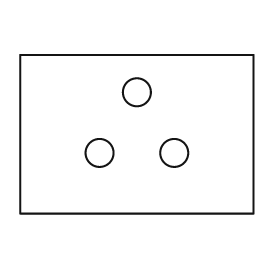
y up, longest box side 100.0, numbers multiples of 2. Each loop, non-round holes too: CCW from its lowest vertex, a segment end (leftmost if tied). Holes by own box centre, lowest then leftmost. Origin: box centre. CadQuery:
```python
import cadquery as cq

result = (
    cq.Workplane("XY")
    .moveTo(-50.0, -34.0)
    .lineTo(50.0, -34.0)
    .lineTo(50.0, 34.0)
    .lineTo(-50.0, 34.0)
    .close()
    .moveTo(-16.0, -8.0)
    .circle(6.0)
    .moveTo(16.0, -8.0)
    .circle(6.0)
    .moveTo(0.0, 18.0)
    .circle(6.0)
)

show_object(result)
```